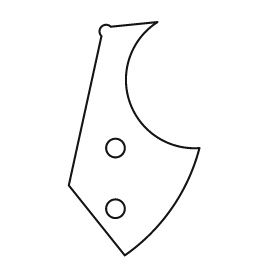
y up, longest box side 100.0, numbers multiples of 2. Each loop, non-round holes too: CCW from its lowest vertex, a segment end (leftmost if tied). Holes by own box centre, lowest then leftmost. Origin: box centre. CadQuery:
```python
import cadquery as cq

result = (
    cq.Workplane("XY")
    .moveTo(-4.0, -50.0)
    .threePointArc((16.0, -30.0), (28.0, -4.0))
    .threePointArc((-2.0, 16.0), (10.0, 50.0))
    .lineTo(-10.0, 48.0)
    .threePointArc((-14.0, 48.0), (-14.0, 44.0))
    .lineTo(-28.0, -20.0)
    .close()
    .moveTo(-8.0, -30.0)
    .circle(4.0)
    .moveTo(-8.0, -4.0)
    .circle(4.0)
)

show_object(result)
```